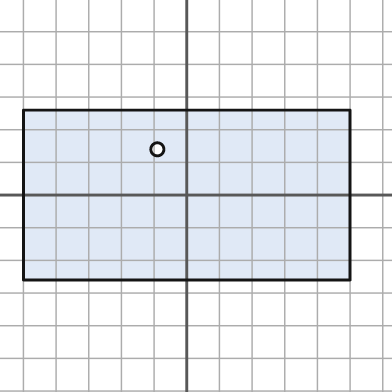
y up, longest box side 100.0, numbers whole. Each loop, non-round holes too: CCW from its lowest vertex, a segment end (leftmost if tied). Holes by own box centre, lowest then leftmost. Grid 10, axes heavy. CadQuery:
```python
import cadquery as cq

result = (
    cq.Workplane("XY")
    .moveTo(-50.0, -26.0)
    .lineTo(50.0, -26.0)
    .lineTo(50.0, 26.0)
    .lineTo(-50.0, 26.0)
    .close()
    .moveTo(-9.0, 14.0)
    .circle(2.0)
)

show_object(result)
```